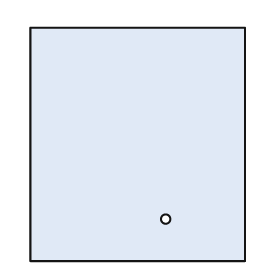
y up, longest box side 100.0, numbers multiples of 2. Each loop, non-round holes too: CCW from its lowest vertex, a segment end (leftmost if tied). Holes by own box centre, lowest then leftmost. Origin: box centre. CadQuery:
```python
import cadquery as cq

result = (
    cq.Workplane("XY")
    .moveTo(-46.0, -50.0)
    .lineTo(46.0, -50.0)
    .lineTo(46.0, 50.0)
    .lineTo(-46.0, 50.0)
    .close()
    .moveTo(12.0, -32.0)
    .circle(2.0)
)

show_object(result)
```